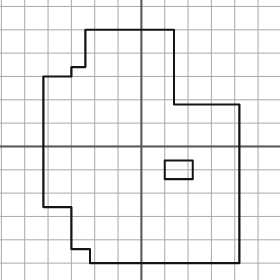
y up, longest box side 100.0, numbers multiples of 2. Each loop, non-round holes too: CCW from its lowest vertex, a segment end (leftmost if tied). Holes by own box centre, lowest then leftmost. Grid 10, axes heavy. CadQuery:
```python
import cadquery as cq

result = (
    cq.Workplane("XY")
    .moveTo(-22.0, -50.0)
    .lineTo(42.0, -50.0)
    .lineTo(42.0, 18.0)
    .lineTo(14.0, 18.0)
    .lineTo(14.0, 50.0)
    .lineTo(-24.0, 50.0)
    .lineTo(-24.0, 34.0)
    .lineTo(-30.0, 34.0)
    .lineTo(-30.0, 30.0)
    .lineTo(-42.0, 30.0)
    .lineTo(-42.0, -26.0)
    .lineTo(-30.0, -26.0)
    .lineTo(-30.0, -44.0)
    .lineTo(-22.0, -44.0)
    .close()
    .moveTo(10.0, -14.0)
    .lineTo(22.0, -14.0)
    .lineTo(22.0, -6.0)
    .lineTo(10.0, -6.0)
    .close()
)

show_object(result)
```